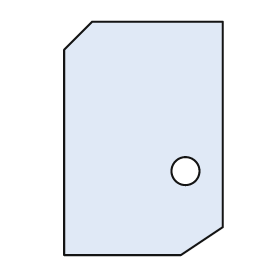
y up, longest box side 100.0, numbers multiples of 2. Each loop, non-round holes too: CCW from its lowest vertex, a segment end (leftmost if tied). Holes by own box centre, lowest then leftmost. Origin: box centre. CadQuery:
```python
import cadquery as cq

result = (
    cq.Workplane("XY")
    .moveTo(-34.0, -50.0)
    .lineTo(16.0, -50.0)
    .lineTo(34.0, -38.0)
    .lineTo(34.0, 50.0)
    .lineTo(-22.0, 50.0)
    .lineTo(-34.0, 38.0)
    .close()
    .moveTo(18.0, -14.0)
    .circle(6.0)
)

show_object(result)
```